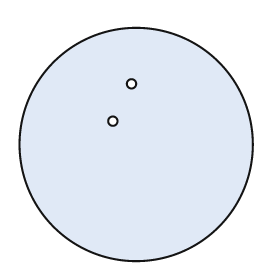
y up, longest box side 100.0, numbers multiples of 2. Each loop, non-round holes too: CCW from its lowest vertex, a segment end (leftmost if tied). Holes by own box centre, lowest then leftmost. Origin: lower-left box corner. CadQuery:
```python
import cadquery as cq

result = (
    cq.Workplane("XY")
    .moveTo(50.0, 50.0)
    .circle(50.0)
    .moveTo(40.0, 60.0)
    .circle(2.0)
    .moveTo(48.0, 76.0)
    .circle(2.0)
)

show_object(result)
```